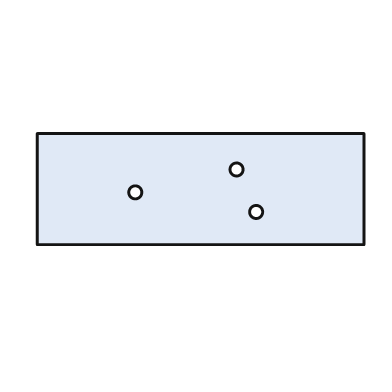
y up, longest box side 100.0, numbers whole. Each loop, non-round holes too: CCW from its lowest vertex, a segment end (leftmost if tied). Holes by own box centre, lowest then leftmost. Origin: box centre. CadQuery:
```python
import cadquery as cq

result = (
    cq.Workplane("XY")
    .moveTo(-50.0, -17.0)
    .lineTo(50.0, -17.0)
    .lineTo(50.0, 17.0)
    .lineTo(-50.0, 17.0)
    .close()
    .moveTo(17.0, -7.0)
    .circle(2.0)
    .moveTo(-20.0, -1.0)
    .circle(2.0)
    .moveTo(11.0, 6.0)
    .circle(2.0)
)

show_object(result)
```